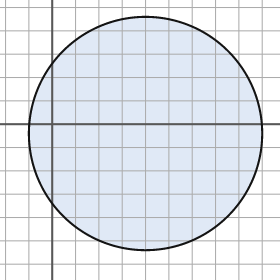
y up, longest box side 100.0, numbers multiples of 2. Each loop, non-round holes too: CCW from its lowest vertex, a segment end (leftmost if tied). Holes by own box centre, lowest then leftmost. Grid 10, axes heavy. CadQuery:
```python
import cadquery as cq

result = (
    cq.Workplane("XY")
    .moveTo(40.0, -4.0)
    .circle(50.0)
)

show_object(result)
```